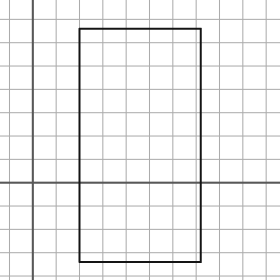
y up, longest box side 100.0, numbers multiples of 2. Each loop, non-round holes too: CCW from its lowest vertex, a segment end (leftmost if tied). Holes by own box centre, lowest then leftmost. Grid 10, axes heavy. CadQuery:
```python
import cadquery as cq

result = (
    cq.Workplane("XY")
    .moveTo(20.0, -34.0)
    .lineTo(72.0, -34.0)
    .lineTo(72.0, 66.0)
    .lineTo(20.0, 66.0)
    .close()
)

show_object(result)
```